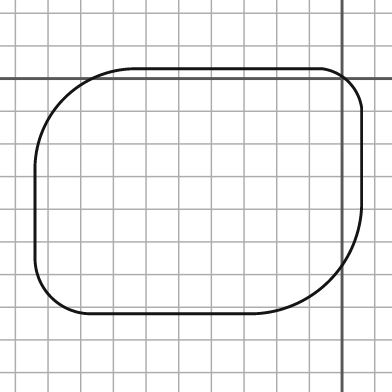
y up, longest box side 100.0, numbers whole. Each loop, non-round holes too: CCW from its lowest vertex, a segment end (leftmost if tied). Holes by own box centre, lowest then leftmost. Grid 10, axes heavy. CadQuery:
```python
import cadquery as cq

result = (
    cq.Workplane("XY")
    .moveTo(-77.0, -72.0)
    .lineTo(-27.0, -72.0)
    .threePointArc((-4.0, -62.0), (6.0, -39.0))
    .lineTo(6.0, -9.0)
    .threePointArc((2.0, -1.0), (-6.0, 3.0))
    .lineTo(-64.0, 3.0)
    .threePointArc((-85.0, -6.0), (-94.0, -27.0))
    .lineTo(-94.0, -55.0)
    .threePointArc((-89.0, -67.0), (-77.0, -72.0))
    .close()
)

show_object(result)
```